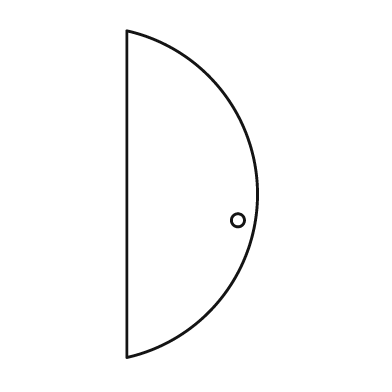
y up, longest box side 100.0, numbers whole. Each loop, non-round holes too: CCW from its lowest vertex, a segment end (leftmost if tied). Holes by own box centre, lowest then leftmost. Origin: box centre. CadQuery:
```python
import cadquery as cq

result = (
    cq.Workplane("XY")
    .moveTo(-20.0, -50.0)
    .threePointArc((20.0, 0.0), (-20.0, 50.0))
    .close()
    .moveTo(14.0, -8.0)
    .circle(2.0)
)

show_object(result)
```